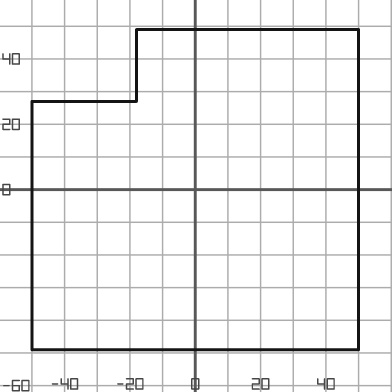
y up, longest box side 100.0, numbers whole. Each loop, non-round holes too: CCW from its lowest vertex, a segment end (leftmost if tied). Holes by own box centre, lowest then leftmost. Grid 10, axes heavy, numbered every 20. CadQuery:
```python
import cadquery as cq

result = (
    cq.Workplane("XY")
    .moveTo(-50.0, -49.0)
    .lineTo(50.0, -49.0)
    .lineTo(50.0, 49.0)
    .lineTo(-18.0, 49.0)
    .lineTo(-18.0, 27.0)
    .lineTo(-50.0, 27.0)
    .close()
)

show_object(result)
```